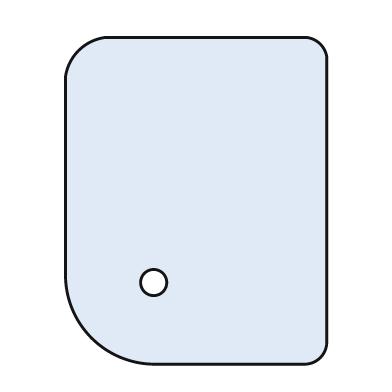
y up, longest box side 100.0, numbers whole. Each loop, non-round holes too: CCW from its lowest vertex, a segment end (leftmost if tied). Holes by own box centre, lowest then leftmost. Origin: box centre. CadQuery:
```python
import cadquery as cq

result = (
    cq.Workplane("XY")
    .moveTo(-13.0, -50.0)
    .lineTo(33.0, -50.0)
    .threePointArc((38.0, -48.0), (40.0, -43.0))
    .lineTo(40.0, 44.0)
    .threePointArc((38.0, 48.0), (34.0, 50.0))
    .lineTo(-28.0, 50.0)
    .threePointArc((-36.0, 46.0), (-40.0, 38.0))
    .lineTo(-40.0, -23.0)
    .threePointArc((-32.0, -42.0), (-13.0, -50.0))
    .close()
    .moveTo(-13.0, -25.0)
    .circle(4.0)
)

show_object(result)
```